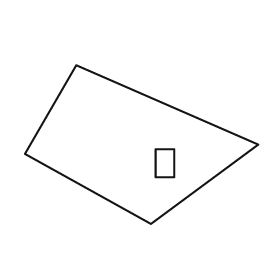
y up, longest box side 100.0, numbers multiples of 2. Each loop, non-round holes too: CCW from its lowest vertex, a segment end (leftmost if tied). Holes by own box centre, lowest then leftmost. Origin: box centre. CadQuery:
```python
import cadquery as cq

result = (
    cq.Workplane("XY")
    .moveTo(4.0, -34.0)
    .lineTo(50.0, 0.0)
    .lineTo(-28.0, 34.0)
    .lineTo(-50.0, -4.0)
    .close()
    .moveTo(6.0, -14.0)
    .lineTo(14.0, -14.0)
    .lineTo(14.0, -2.0)
    .lineTo(6.0, -2.0)
    .close()
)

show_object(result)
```